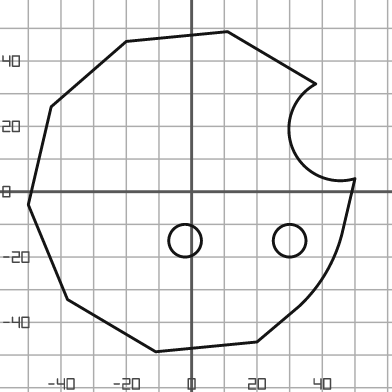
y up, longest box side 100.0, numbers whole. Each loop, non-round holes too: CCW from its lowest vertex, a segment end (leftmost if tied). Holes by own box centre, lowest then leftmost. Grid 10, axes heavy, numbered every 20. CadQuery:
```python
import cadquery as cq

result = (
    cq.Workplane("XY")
    .moveTo(-11.0, -49.0)
    .lineTo(20.0, -46.0)
    .lineTo(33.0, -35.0)
    .threePointArc((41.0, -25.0), (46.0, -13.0))
    .lineTo(50.0, 4.0)
    .threePointArc((31.0, 13.0), (38.0, 33.0))
    .lineTo(11.0, 49.0)
    .lineTo(-20.0, 46.0)
    .lineTo(-43.0, 26.0)
    .lineTo(-50.0, -4.0)
    .lineTo(-38.0, -33.0)
    .close()
    .moveTo(-2.0, -15.0)
    .circle(5.0)
    .moveTo(30.0, -15.0)
    .circle(5.0)
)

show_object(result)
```